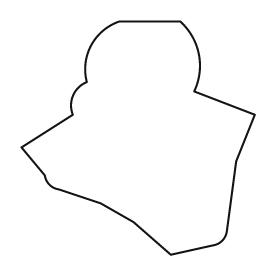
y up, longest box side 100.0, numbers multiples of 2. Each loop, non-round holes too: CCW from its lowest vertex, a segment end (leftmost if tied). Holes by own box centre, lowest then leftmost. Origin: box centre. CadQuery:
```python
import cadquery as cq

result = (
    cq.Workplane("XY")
    .moveTo(14.0, -50.0)
    .lineTo(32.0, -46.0)
    .threePointArc((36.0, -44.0), (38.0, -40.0))
    .lineTo(42.0, -10.0)
    .lineTo(50.0, 10.0)
    .lineTo(24.0, 20.0)
    .threePointArc((26.0, 36.0), (18.0, 50.0))
    .lineTo(-8.0, 50.0)
    .threePointArc((-20.0, 40.0), (-22.0, 24.0))
    .threePointArc((-28.0, 18.0), (-28.0, 10.0))
    .lineTo(-50.0, -4.0)
    .lineTo(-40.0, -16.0)
    .threePointArc((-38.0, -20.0), (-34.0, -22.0))
    .lineTo(-16.0, -28.0)
    .lineTo(-2.0, -36.0)
    .close()
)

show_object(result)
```